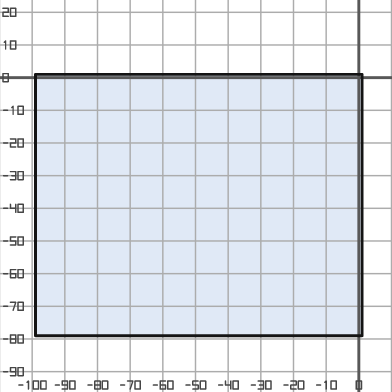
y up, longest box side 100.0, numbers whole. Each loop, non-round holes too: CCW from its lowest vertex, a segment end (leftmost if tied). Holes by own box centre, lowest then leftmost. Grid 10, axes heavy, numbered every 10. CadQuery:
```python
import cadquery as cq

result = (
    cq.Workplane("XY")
    .moveTo(-99.0, -79.0)
    .lineTo(1.0, -79.0)
    .lineTo(1.0, 1.0)
    .lineTo(-99.0, 1.0)
    .close()
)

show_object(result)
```